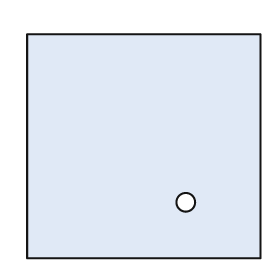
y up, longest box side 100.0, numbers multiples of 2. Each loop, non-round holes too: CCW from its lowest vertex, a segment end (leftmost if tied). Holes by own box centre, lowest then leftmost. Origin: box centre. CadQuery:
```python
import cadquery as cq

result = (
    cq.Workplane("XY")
    .moveTo(-50.0, -48.0)
    .lineTo(50.0, -48.0)
    .lineTo(50.0, 48.0)
    .lineTo(-50.0, 48.0)
    .close()
    .moveTo(18.0, -24.0)
    .circle(4.0)
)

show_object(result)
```